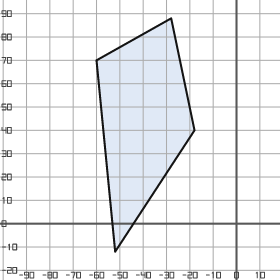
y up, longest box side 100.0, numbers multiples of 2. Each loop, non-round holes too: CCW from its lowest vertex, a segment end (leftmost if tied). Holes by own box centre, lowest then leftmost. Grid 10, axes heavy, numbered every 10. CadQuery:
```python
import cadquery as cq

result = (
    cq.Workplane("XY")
    .moveTo(-52.0, -12.0)
    .lineTo(-18.0, 40.0)
    .lineTo(-28.0, 88.0)
    .lineTo(-60.0, 70.0)
    .close()
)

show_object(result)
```